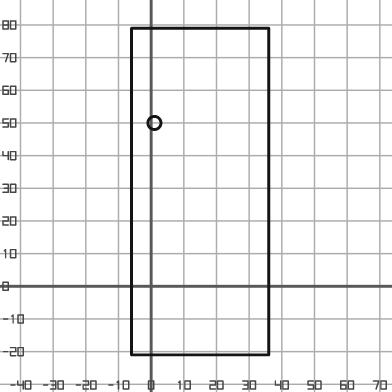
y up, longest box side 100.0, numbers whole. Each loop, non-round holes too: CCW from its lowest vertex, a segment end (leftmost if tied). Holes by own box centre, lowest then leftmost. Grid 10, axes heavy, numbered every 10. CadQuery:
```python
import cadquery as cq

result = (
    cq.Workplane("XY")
    .moveTo(-6.0, -21.0)
    .lineTo(36.0, -21.0)
    .lineTo(36.0, 79.0)
    .lineTo(-6.0, 79.0)
    .close()
    .moveTo(1.0, 50.0)
    .circle(2.0)
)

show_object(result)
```